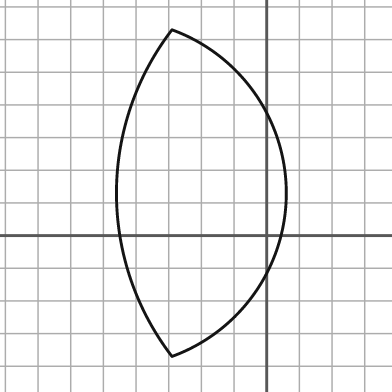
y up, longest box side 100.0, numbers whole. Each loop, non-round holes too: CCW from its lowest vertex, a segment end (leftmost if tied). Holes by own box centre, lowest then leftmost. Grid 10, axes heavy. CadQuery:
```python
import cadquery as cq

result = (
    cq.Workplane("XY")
    .moveTo(-29.0, -37.0)
    .threePointArc((6.0, 13.0), (-29.0, 63.0))
    .threePointArc((-46.0, 13.0), (-29.0, -37.0))
    .close()
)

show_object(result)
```